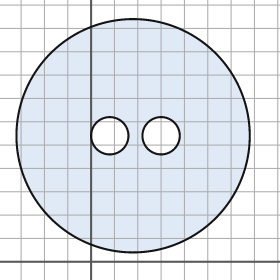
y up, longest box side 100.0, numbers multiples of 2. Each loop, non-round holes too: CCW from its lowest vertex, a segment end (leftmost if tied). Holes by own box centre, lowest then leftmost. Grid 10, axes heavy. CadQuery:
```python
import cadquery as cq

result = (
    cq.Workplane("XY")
    .moveTo(18.0, 54.0)
    .circle(50.0)
    .moveTo(8.0, 54.0)
    .circle(8.0)
    .moveTo(30.0, 54.0)
    .circle(8.0)
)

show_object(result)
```